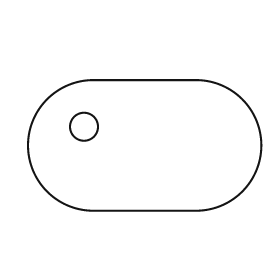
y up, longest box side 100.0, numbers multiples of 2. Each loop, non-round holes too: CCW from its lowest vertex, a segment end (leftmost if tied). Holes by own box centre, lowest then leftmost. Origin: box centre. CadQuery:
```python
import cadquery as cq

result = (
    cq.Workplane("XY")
    .moveTo(-22.0, -28.0)
    .lineTo(22.0, -28.0)
    .threePointArc((50.0, 0.0), (22.0, 28.0))
    .lineTo(-22.0, 28.0)
    .threePointArc((-50.0, 0.0), (-22.0, -28.0))
    .close()
    .moveTo(-26.0, 8.0)
    .circle(6.0)
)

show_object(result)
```